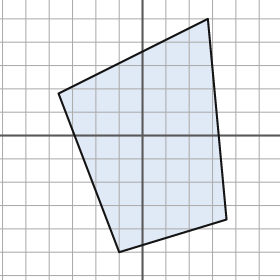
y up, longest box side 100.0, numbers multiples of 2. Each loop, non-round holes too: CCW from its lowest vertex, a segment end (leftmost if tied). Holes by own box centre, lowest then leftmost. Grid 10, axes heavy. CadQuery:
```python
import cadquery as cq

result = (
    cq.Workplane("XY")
    .moveTo(-10.0, -50.0)
    .lineTo(36.0, -36.0)
    .lineTo(28.0, 50.0)
    .lineTo(-36.0, 18.0)
    .close()
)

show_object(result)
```